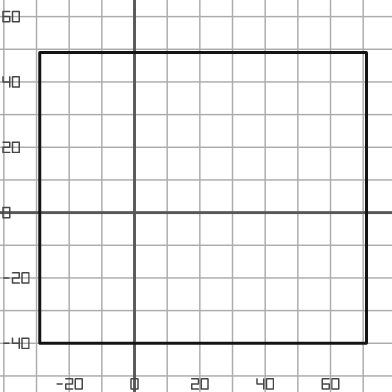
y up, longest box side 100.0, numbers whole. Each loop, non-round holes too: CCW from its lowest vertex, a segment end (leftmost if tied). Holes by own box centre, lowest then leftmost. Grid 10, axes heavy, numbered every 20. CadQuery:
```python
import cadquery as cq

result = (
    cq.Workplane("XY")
    .moveTo(-29.0, -40.0)
    .lineTo(71.0, -40.0)
    .lineTo(71.0, 49.0)
    .lineTo(-29.0, 49.0)
    .close()
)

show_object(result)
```